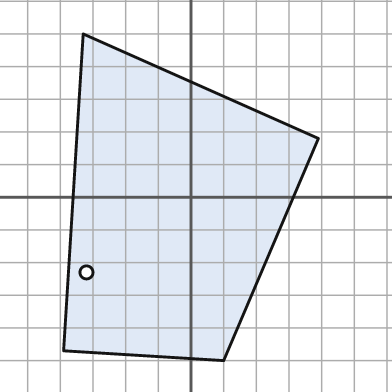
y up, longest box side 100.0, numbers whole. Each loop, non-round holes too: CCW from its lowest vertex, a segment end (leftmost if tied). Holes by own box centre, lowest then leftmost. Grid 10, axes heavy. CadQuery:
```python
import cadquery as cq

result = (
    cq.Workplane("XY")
    .moveTo(10.0, -50.0)
    .lineTo(39.0, 18.0)
    .lineTo(-33.0, 50.0)
    .lineTo(-39.0, -47.0)
    .close()
    .moveTo(-32.0, -23.0)
    .circle(2.0)
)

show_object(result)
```